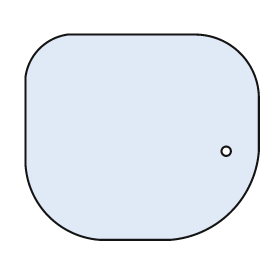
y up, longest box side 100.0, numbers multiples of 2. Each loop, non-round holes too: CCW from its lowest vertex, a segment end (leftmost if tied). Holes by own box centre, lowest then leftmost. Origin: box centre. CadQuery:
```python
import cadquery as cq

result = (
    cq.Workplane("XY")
    .moveTo(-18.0, -44.0)
    .lineTo(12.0, -44.0)
    .threePointArc((38.0, -32.0), (50.0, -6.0))
    .lineTo(50.0, 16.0)
    .threePointArc((42.0, 36.0), (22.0, 44.0))
    .lineTo(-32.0, 44.0)
    .threePointArc((-44.0, 38.0), (-50.0, 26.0))
    .lineTo(-50.0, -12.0)
    .threePointArc((-40.0, -34.0), (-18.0, -44.0))
    .close()
    .moveTo(36.0, -6.0)
    .circle(2.0)
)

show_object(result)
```